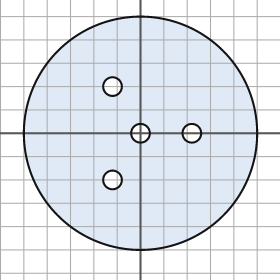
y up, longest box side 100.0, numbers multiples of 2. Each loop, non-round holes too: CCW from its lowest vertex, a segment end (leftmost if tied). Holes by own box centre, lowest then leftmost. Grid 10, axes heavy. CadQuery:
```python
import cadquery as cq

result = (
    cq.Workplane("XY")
    .moveTo(0.0, 0.0)
    .circle(50.0)
    .moveTo(-12.0, -20.0)
    .circle(4.0)
    .moveTo(0.0, 0.0)
    .circle(4.0)
    .moveTo(22.0, 0.0)
    .circle(4.0)
    .moveTo(-12.0, 20.0)
    .circle(4.0)
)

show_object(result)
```